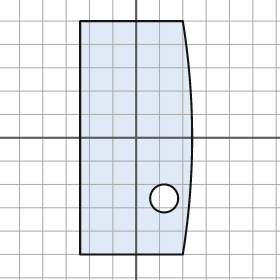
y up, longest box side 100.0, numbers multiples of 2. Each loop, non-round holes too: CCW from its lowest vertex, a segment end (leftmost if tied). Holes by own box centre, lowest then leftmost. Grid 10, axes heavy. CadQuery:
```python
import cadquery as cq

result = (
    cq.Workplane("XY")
    .moveTo(-24.0, -50.0)
    .lineTo(20.0, -50.0)
    .threePointArc((24.0, 0.0), (20.0, 50.0))
    .lineTo(-24.0, 50.0)
    .close()
    .moveTo(12.0, -26.0)
    .circle(6.0)
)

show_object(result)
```